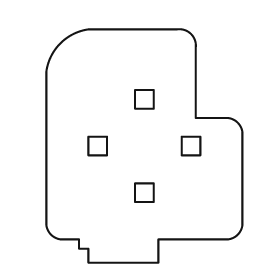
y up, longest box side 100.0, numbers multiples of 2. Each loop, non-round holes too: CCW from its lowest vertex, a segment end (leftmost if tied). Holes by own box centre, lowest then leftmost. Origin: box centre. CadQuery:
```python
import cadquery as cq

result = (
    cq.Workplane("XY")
    .moveTo(-24.0, -50.0)
    .lineTo(6.0, -50.0)
    .lineTo(6.0, -40.0)
    .lineTo(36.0, -40.0)
    .threePointArc((40.0, -38.0), (42.0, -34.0))
    .lineTo(42.0, 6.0)
    .threePointArc((40.0, 10.0), (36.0, 12.0))
    .lineTo(22.0, 12.0)
    .lineTo(22.0, 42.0)
    .threePointArc((20.0, 48.0), (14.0, 50.0))
    .lineTo(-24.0, 50.0)
    .threePointArc((-36.0, 44.0), (-42.0, 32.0))
    .lineTo(-42.0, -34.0)
    .threePointArc((-40.0, -38.0), (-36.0, -40.0))
    .lineTo(-28.0, -40.0)
    .lineTo(-28.0, -44.0)
    .lineTo(-24.0, -44.0)
    .close()
    .moveTo(-4.0, -24.0)
    .lineTo(4.0, -24.0)
    .lineTo(4.0, -16.0)
    .lineTo(-4.0, -16.0)
    .close()
    .moveTo(-24.0, -4.0)
    .lineTo(-16.0, -4.0)
    .lineTo(-16.0, 4.0)
    .lineTo(-24.0, 4.0)
    .close()
    .moveTo(16.0, -4.0)
    .lineTo(24.0, -4.0)
    .lineTo(24.0, 4.0)
    .lineTo(16.0, 4.0)
    .close()
    .moveTo(-4.0, 16.0)
    .lineTo(4.0, 16.0)
    .lineTo(4.0, 24.0)
    .lineTo(-4.0, 24.0)
    .close()
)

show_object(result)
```